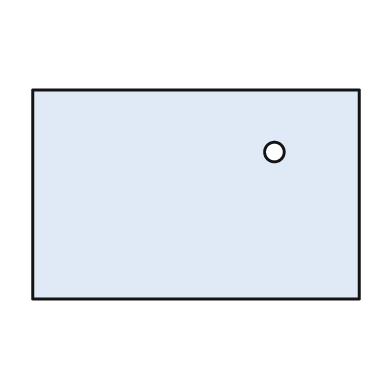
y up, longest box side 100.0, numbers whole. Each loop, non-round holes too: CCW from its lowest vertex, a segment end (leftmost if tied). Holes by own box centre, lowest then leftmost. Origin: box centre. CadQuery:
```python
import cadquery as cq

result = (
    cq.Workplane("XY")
    .moveTo(-50.0, -32.0)
    .lineTo(50.0, -32.0)
    .lineTo(50.0, 32.0)
    .lineTo(-50.0, 32.0)
    .close()
    .moveTo(24.0, 13.0)
    .circle(3.0)
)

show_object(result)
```